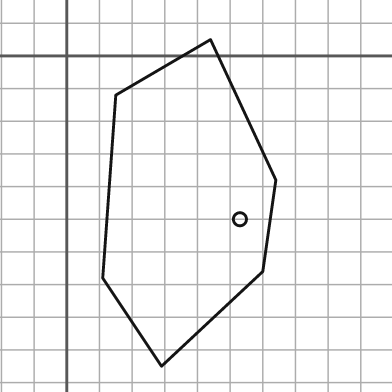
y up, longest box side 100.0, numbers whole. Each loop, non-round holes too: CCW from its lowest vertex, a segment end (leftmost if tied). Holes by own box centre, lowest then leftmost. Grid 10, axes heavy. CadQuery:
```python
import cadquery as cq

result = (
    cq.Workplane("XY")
    .moveTo(29.0, -95.0)
    .lineTo(60.0, -66.0)
    .lineTo(64.0, -38.0)
    .lineTo(44.0, 5.0)
    .lineTo(15.0, -12.0)
    .lineTo(11.0, -68.0)
    .close()
    .moveTo(53.0, -50.0)
    .circle(2.0)
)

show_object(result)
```